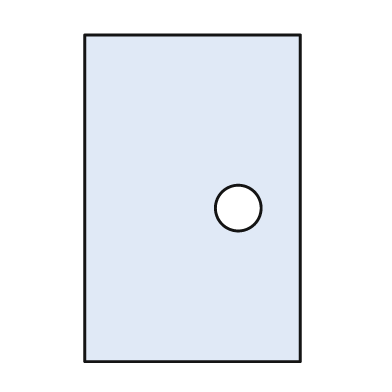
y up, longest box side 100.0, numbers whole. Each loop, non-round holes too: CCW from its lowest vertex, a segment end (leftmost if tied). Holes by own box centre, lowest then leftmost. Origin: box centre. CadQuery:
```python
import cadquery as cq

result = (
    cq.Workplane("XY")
    .moveTo(-33.0, -50.0)
    .lineTo(33.0, -50.0)
    .lineTo(33.0, 50.0)
    .lineTo(-33.0, 50.0)
    .close()
    .moveTo(14.0, -3.0)
    .circle(7.0)
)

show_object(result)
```